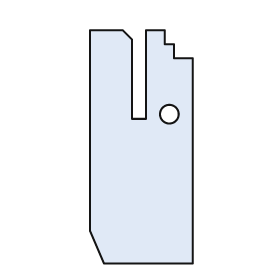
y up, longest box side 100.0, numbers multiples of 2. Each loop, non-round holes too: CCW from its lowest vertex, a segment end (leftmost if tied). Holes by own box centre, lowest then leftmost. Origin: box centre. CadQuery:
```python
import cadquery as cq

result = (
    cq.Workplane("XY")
    .moveTo(-16.0, -50.0)
    .lineTo(22.0, -50.0)
    .lineTo(22.0, 38.0)
    .lineTo(14.0, 38.0)
    .lineTo(14.0, 44.0)
    .lineTo(10.0, 44.0)
    .lineTo(10.0, 50.0)
    .lineTo(2.0, 50.0)
    .lineTo(2.0, 12.0)
    .lineTo(-4.0, 12.0)
    .lineTo(-4.0, 46.0)
    .lineTo(-8.0, 50.0)
    .lineTo(-22.0, 50.0)
    .lineTo(-22.0, -36.0)
    .close()
    .moveTo(12.0, 14.0)
    .circle(4.0)
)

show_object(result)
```